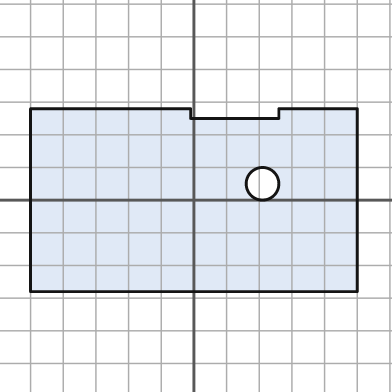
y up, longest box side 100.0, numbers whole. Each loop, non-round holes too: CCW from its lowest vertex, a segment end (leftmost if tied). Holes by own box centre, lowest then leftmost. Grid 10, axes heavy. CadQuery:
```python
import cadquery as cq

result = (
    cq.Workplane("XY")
    .moveTo(-50.0, -28.0)
    .lineTo(50.0, -28.0)
    .lineTo(50.0, 28.0)
    .lineTo(26.0, 28.0)
    .lineTo(26.0, 25.0)
    .lineTo(-1.0, 25.0)
    .lineTo(-1.0, 28.0)
    .lineTo(-50.0, 28.0)
    .close()
    .moveTo(21.0, 5.0)
    .circle(5.0)
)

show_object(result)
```